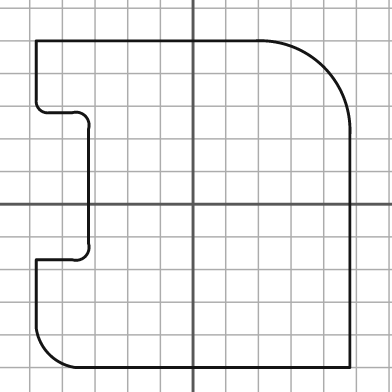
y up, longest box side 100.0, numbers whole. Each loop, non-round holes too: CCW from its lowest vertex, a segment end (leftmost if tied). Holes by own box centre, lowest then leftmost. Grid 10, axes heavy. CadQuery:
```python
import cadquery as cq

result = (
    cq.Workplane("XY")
    .moveTo(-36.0, -50.0)
    .lineTo(48.0, -50.0)
    .lineTo(48.0, 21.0)
    .threePointArc((40.0, 42.0), (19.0, 50.0))
    .lineTo(-48.0, 50.0)
    .lineTo(-48.0, 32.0)
    .threePointArc((-47.0, 29.0), (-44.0, 28.0))
    .lineTo(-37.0, 28.0)
    .threePointArc((-33.0, 27.0), (-32.0, 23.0))
    .lineTo(-32.0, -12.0)
    .threePointArc((-33.0, -16.0), (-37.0, -17.0))
    .lineTo(-48.0, -17.0)
    .lineTo(-48.0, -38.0)
    .threePointArc((-44.0, -46.0), (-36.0, -50.0))
    .close()
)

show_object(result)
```